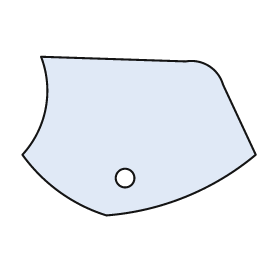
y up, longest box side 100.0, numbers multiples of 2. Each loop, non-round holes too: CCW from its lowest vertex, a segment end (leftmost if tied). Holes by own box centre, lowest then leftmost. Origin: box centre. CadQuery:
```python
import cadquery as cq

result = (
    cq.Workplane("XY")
    .moveTo(-14.0, -34.0)
    .threePointArc((20.0, -26.0), (50.0, -8.0))
    .lineTo(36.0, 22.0)
    .threePointArc((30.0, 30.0), (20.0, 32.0))
    .lineTo(-42.0, 34.0)
    .threePointArc((-40.0, 12.0), (-50.0, -8.0))
    .threePointArc((-34.0, -24.0), (-14.0, -34.0))
    .close()
    .moveTo(-6.0, -18.0)
    .circle(4.0)
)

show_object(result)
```